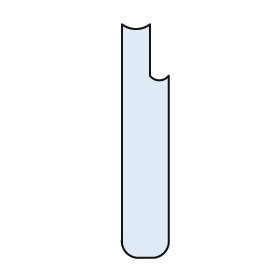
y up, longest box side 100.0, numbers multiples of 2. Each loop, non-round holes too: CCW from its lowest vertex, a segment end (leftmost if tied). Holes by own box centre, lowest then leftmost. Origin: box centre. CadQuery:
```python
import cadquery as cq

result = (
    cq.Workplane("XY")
    .moveTo(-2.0, -50.0)
    .lineTo(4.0, -50.0)
    .threePointArc((8.0, -48.0), (10.0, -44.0))
    .lineTo(10.0, 28.0)
    .threePointArc((6.0, 26.0), (2.0, 28.0))
    .lineTo(2.0, 50.0)
    .threePointArc((-4.0, 48.0), (-10.0, 50.0))
    .lineTo(-10.0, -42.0)
    .threePointArc((-8.0, -48.0), (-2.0, -50.0))
    .close()
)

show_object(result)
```